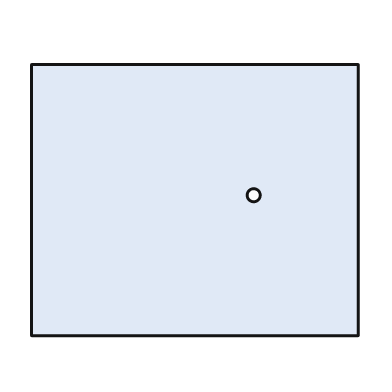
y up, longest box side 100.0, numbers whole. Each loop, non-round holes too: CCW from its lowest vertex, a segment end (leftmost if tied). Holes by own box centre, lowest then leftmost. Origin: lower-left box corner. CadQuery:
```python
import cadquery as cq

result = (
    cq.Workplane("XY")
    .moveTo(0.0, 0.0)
    .lineTo(100.0, 0.0)
    .lineTo(100.0, 83.0)
    .lineTo(0.0, 83.0)
    .close()
    .moveTo(68.0, 43.0)
    .circle(2.0)
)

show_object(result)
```